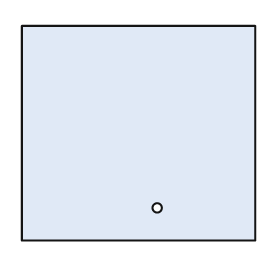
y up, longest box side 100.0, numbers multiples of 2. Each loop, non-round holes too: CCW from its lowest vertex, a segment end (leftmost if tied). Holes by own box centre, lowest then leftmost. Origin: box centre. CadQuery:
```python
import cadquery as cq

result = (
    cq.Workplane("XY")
    .moveTo(-50.0, -46.0)
    .lineTo(50.0, -46.0)
    .lineTo(50.0, 46.0)
    .lineTo(-50.0, 46.0)
    .close()
    .moveTo(8.0, -32.0)
    .circle(2.0)
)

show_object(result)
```